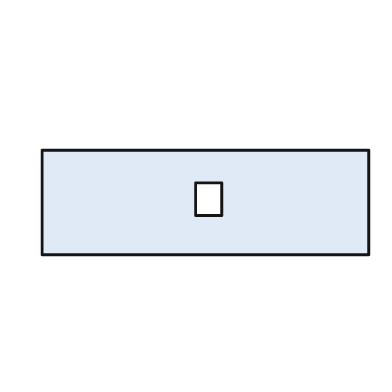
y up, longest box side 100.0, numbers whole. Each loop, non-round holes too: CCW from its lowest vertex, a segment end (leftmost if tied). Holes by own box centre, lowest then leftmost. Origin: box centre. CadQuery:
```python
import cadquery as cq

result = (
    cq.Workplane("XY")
    .moveTo(-50.0, -16.0)
    .lineTo(50.0, -16.0)
    .lineTo(50.0, 16.0)
    .lineTo(-50.0, 16.0)
    .close()
    .moveTo(-3.0, -4.0)
    .lineTo(5.0, -4.0)
    .lineTo(5.0, 6.0)
    .lineTo(-3.0, 6.0)
    .close()
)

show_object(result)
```